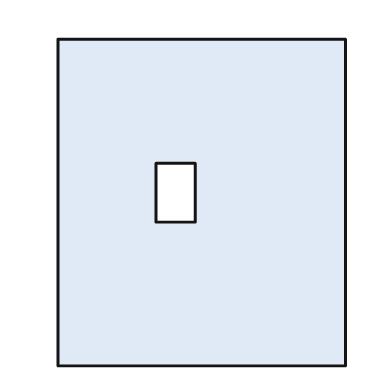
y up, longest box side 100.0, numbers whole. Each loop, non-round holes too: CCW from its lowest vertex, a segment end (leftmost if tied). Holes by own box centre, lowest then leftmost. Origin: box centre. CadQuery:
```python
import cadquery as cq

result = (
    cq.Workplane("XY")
    .moveTo(-44.0, -50.0)
    .lineTo(44.0, -50.0)
    .lineTo(44.0, 50.0)
    .lineTo(-44.0, 50.0)
    .close()
    .moveTo(-14.0, -6.0)
    .lineTo(-2.0, -6.0)
    .lineTo(-2.0, 12.0)
    .lineTo(-14.0, 12.0)
    .close()
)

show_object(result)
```